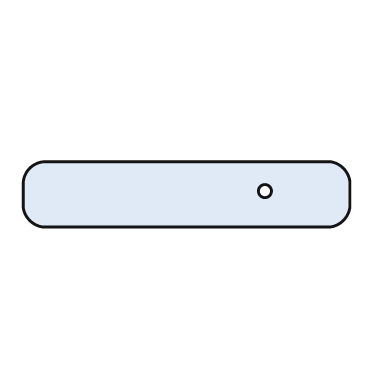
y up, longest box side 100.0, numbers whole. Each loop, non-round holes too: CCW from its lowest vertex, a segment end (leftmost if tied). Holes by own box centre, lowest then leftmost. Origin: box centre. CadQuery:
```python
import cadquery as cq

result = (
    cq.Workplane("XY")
    .moveTo(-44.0, -10.0)
    .lineTo(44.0, -10.0)
    .threePointArc((48.0, -8.0), (50.0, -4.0))
    .lineTo(50.0, 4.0)
    .threePointArc((48.0, 8.0), (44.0, 10.0))
    .lineTo(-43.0, 10.0)
    .threePointArc((-48.0, 8.0), (-50.0, 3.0))
    .lineTo(-50.0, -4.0)
    .threePointArc((-48.0, -8.0), (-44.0, -10.0))
    .close()
    .moveTo(24.0, 1.0)
    .circle(2.0)
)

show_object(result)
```